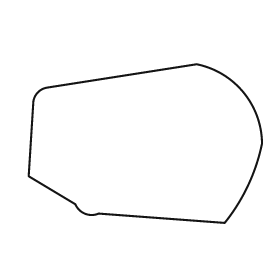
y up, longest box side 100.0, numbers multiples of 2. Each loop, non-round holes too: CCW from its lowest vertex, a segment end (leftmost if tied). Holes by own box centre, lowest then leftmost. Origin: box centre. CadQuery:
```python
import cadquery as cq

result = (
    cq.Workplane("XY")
    .moveTo(34.0, -34.0)
    .threePointArc((44.0, -18.0), (50.0, 0.0))
    .threePointArc((42.0, 22.0), (22.0, 34.0))
    .lineTo(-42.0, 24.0)
    .threePointArc((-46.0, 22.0), (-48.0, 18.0))
    .lineTo(-50.0, -14.0)
    .lineTo(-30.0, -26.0)
    .threePointArc((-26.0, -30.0), (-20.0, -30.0))
    .close()
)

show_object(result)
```